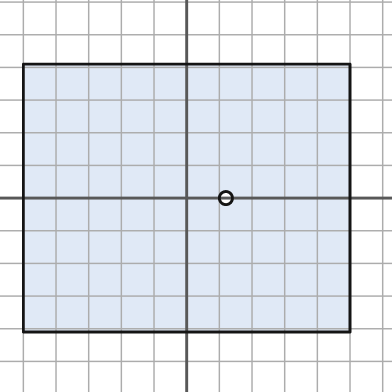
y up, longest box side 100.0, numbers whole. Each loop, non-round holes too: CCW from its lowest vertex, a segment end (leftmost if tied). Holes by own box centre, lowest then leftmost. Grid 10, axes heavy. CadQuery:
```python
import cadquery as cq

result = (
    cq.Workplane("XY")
    .moveTo(-50.0, -41.0)
    .lineTo(50.0, -41.0)
    .lineTo(50.0, 41.0)
    .lineTo(-50.0, 41.0)
    .close()
    .moveTo(12.0, 0.0)
    .circle(2.0)
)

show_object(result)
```